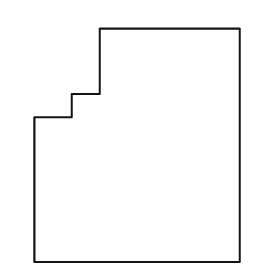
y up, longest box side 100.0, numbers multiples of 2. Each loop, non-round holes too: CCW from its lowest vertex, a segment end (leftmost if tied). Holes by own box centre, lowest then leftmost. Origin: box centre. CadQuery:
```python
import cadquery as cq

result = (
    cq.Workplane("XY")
    .moveTo(-44.0, -50.0)
    .lineTo(44.0, -50.0)
    .lineTo(44.0, 50.0)
    .lineTo(-16.0, 50.0)
    .lineTo(-16.0, 22.0)
    .lineTo(-28.0, 22.0)
    .lineTo(-28.0, 12.0)
    .lineTo(-44.0, 12.0)
    .close()
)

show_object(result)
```